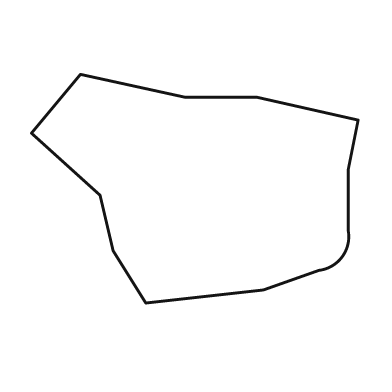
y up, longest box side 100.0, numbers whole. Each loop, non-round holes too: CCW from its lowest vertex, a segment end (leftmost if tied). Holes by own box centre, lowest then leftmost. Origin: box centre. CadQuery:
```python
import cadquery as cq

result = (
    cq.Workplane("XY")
    .moveTo(-15.0, -35.0)
    .lineTo(21.0, -31.0)
    .lineTo(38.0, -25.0)
    .threePointArc((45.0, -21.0), (47.0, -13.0))
    .lineTo(47.0, 6.0)
    .lineTo(50.0, 21.0)
    .lineTo(19.0, 28.0)
    .lineTo(-3.0, 28.0)
    .lineTo(-35.0, 35.0)
    .lineTo(-50.0, 17.0)
    .lineTo(-29.0, -2.0)
    .lineTo(-25.0, -19.0)
    .close()
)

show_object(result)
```